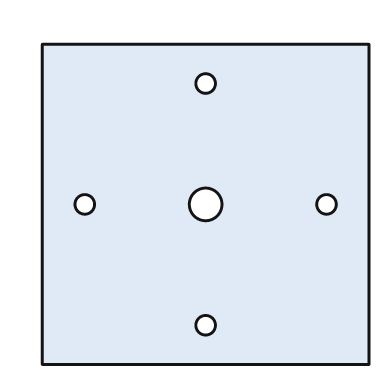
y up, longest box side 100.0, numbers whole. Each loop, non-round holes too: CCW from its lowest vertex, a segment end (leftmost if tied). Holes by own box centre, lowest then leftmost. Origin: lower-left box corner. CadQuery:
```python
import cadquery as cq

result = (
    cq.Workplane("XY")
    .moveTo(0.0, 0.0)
    .lineTo(100.0, 0.0)
    .lineTo(100.0, 98.0)
    .lineTo(0.0, 98.0)
    .close()
    .moveTo(50.0, 12.0)
    .circle(3.0)
    .moveTo(13.0, 49.0)
    .circle(3.0)
    .moveTo(50.0, 49.0)
    .circle(5.0)
    .moveTo(87.0, 49.0)
    .circle(3.0)
    .moveTo(50.0, 86.0)
    .circle(3.0)
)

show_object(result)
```